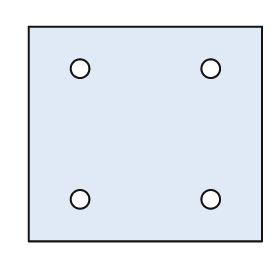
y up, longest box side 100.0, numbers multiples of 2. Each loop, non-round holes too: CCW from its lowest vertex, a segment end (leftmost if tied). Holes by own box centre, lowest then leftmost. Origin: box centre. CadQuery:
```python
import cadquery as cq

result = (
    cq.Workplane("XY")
    .moveTo(-50.0, -46.0)
    .lineTo(50.0, -46.0)
    .lineTo(50.0, 46.0)
    .lineTo(-50.0, 46.0)
    .close()
    .moveTo(-28.0, -28.0)
    .circle(4.0)
    .moveTo(28.0, -28.0)
    .circle(4.0)
    .moveTo(-28.0, 28.0)
    .circle(4.0)
    .moveTo(28.0, 28.0)
    .circle(4.0)
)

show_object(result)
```